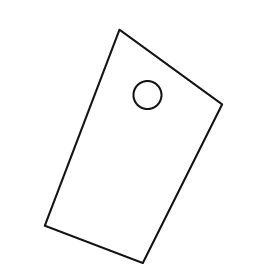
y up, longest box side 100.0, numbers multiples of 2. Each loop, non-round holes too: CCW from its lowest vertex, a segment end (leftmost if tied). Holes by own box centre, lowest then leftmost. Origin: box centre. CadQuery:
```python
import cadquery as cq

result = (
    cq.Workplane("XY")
    .moveTo(4.0, -50.0)
    .lineTo(38.0, 18.0)
    .lineTo(-6.0, 50.0)
    .lineTo(-38.0, -34.0)
    .close()
    .moveTo(6.0, 22.0)
    .circle(6.0)
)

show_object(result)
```